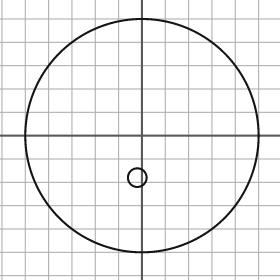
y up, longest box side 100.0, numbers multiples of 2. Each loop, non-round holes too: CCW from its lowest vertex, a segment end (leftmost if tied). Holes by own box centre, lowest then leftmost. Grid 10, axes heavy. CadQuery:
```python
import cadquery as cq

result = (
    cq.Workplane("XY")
    .moveTo(0.0, 0.0)
    .circle(50.0)
    .moveTo(-2.0, -18.0)
    .circle(4.0)
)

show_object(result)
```